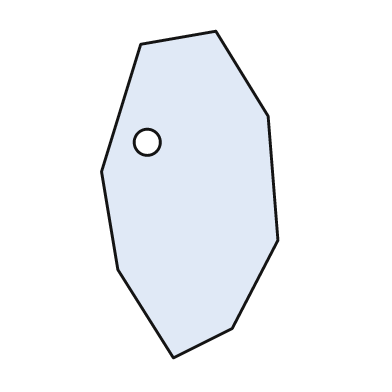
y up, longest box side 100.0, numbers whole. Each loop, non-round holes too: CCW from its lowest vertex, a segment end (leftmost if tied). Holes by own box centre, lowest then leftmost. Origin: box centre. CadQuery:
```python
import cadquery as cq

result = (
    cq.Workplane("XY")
    .moveTo(-5.0, -50.0)
    .lineTo(13.0, -41.0)
    .lineTo(27.0, -14.0)
    .lineTo(24.0, 24.0)
    .lineTo(8.0, 50.0)
    .lineTo(-15.0, 46.0)
    .lineTo(-27.0, 7.0)
    .lineTo(-22.0, -23.0)
    .close()
    .moveTo(-13.0, 16.0)
    .circle(4.0)
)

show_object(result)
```